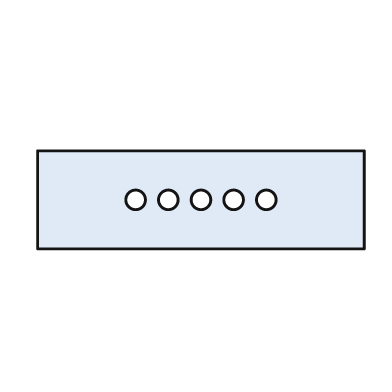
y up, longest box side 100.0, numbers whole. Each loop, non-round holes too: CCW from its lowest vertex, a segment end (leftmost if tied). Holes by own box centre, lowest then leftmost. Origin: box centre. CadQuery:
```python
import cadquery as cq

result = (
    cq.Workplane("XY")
    .moveTo(-50.0, -15.0)
    .lineTo(50.0, -15.0)
    .lineTo(50.0, 15.0)
    .lineTo(-50.0, 15.0)
    .close()
    .moveTo(-20.0, 0.0)
    .circle(3.0)
    .moveTo(-10.0, 0.0)
    .circle(3.0)
    .moveTo(0.0, 0.0)
    .circle(3.0)
    .moveTo(10.0, 0.0)
    .circle(3.0)
    .moveTo(20.0, 0.0)
    .circle(3.0)
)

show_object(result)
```